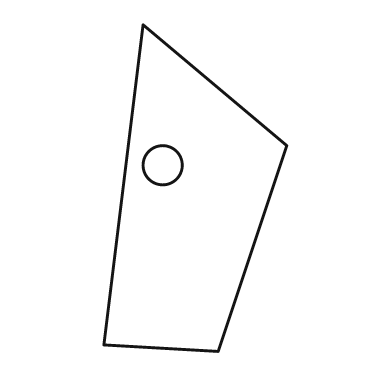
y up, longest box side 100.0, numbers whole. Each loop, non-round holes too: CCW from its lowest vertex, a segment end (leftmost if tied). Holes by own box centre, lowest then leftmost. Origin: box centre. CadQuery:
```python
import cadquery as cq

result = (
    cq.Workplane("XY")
    .moveTo(7.0, -50.0)
    .lineTo(28.0, 13.0)
    .lineTo(-16.0, 50.0)
    .lineTo(-28.0, -48.0)
    .close()
    .moveTo(-10.0, 7.0)
    .circle(6.0)
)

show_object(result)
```